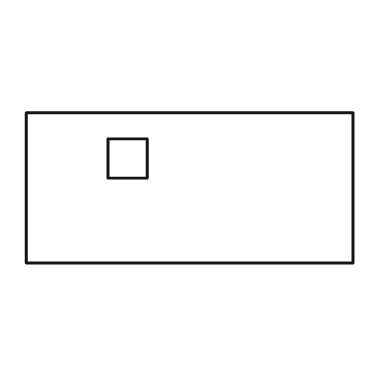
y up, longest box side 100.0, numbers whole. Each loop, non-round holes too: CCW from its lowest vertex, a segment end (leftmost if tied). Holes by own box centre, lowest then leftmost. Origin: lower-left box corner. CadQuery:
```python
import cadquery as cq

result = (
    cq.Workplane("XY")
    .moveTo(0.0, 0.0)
    .lineTo(100.0, 0.0)
    .lineTo(100.0, 46.0)
    .lineTo(0.0, 46.0)
    .close()
    .moveTo(25.0, 26.0)
    .lineTo(37.0, 26.0)
    .lineTo(37.0, 38.0)
    .lineTo(25.0, 38.0)
    .close()
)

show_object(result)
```